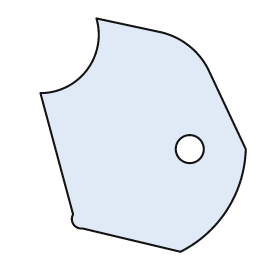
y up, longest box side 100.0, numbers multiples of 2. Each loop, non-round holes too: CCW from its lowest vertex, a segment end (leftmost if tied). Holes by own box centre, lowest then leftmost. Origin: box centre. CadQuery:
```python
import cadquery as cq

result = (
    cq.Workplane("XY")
    .moveTo(16.0, -50.0)
    .threePointArc((36.0, -32.0), (44.0, -6.0))
    .lineTo(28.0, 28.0)
    .threePointArc((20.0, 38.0), (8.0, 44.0))
    .lineTo(-20.0, 50.0)
    .threePointArc((-24.0, 28.0), (-44.0, 18.0))
    .lineTo(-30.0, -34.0)
    .threePointArc((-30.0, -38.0), (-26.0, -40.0))
    .close()
    .moveTo(20.0, -6.0)
    .circle(6.0)
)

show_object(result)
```